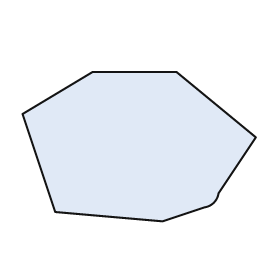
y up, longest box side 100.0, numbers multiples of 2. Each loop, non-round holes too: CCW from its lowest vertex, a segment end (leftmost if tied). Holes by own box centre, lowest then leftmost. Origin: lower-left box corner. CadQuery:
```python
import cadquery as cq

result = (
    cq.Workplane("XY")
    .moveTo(60.0, 0.0)
    .lineTo(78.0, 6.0)
    .threePointArc((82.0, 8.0), (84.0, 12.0))
    .lineTo(100.0, 36.0)
    .lineTo(66.0, 64.0)
    .lineTo(30.0, 64.0)
    .lineTo(0.0, 46.0)
    .lineTo(14.0, 4.0)
    .close()
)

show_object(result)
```